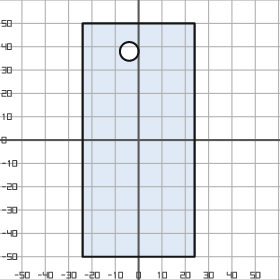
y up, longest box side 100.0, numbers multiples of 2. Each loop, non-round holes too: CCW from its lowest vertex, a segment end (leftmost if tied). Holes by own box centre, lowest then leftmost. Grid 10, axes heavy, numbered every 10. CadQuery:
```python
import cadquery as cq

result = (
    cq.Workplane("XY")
    .moveTo(-24.0, -50.0)
    .lineTo(24.0, -50.0)
    .lineTo(24.0, 50.0)
    .lineTo(-24.0, 50.0)
    .close()
    .moveTo(-4.0, 38.0)
    .circle(4.0)
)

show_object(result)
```